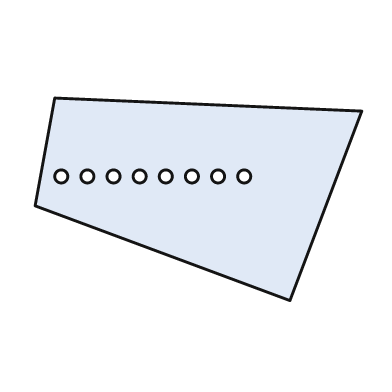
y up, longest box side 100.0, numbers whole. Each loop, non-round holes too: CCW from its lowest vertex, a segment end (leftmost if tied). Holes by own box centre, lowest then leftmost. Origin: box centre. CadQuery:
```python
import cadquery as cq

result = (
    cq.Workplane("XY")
    .moveTo(28.0, -31.0)
    .lineTo(50.0, 27.0)
    .lineTo(-44.0, 31.0)
    .lineTo(-50.0, -2.0)
    .close()
    .moveTo(-42.0, 7.0)
    .circle(2.0)
    .moveTo(-34.0, 7.0)
    .circle(2.0)
    .moveTo(-26.0, 7.0)
    .circle(2.0)
    .moveTo(-18.0, 7.0)
    .circle(2.0)
    .moveTo(-10.0, 7.0)
    .circle(2.0)
    .moveTo(-2.0, 7.0)
    .circle(2.0)
    .moveTo(6.0, 7.0)
    .circle(2.0)
    .moveTo(14.0, 7.0)
    .circle(2.0)
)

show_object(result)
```